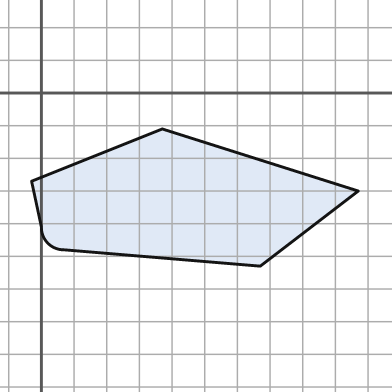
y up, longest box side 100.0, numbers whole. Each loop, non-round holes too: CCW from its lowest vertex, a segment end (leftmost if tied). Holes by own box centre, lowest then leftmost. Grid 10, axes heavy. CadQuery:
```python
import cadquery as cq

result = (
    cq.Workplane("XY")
    .moveTo(67.0, -53.0)
    .lineTo(97.0, -30.0)
    .lineTo(37.0, -11.0)
    .lineTo(-3.0, -27.0)
    .lineTo(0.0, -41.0)
    .threePointArc((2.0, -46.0), (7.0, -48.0))
    .close()
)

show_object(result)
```